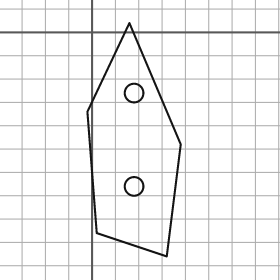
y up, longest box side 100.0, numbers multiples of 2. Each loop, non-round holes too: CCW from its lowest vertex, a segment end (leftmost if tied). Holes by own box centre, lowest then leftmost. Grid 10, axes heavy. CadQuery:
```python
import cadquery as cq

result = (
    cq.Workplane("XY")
    .moveTo(32.0, -96.0)
    .lineTo(38.0, -48.0)
    .lineTo(16.0, 4.0)
    .lineTo(-2.0, -34.0)
    .lineTo(2.0, -86.0)
    .close()
    .moveTo(18.0, -66.0)
    .circle(4.0)
    .moveTo(18.0, -26.0)
    .circle(4.0)
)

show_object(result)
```